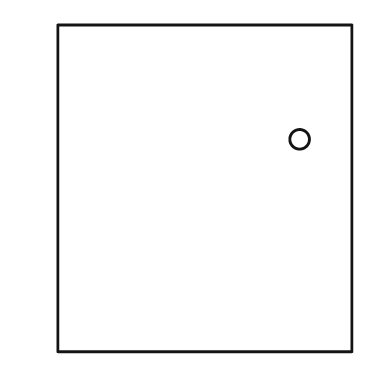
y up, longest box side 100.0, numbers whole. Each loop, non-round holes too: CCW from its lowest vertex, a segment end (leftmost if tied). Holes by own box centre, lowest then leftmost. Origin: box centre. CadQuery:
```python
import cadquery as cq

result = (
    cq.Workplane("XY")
    .moveTo(-45.0, -50.0)
    .lineTo(45.0, -50.0)
    .lineTo(45.0, 50.0)
    .lineTo(-45.0, 50.0)
    .close()
    .moveTo(29.0, 15.0)
    .circle(3.0)
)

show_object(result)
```